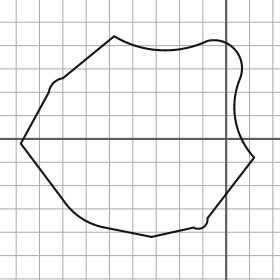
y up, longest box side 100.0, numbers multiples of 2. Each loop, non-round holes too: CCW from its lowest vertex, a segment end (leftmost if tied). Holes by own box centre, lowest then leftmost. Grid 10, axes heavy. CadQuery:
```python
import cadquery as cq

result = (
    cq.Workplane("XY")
    .moveTo(-32.0, -42.0)
    .lineTo(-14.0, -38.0)
    .threePointArc((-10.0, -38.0), (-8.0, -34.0))
    .lineTo(12.0, -8.0)
    .threePointArc((4.0, 8.0), (6.0, 26.0))
    .threePointArc((4.0, 38.0), (-8.0, 42.0))
    .threePointArc((-28.0, 38.0), (-48.0, 44.0))
    .lineTo(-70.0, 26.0)
    .threePointArc((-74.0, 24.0), (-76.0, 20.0))
    .lineTo(-88.0, -2.0)
    .lineTo(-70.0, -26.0)
    .threePointArc((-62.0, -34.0), (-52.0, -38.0))
    .close()
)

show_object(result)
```